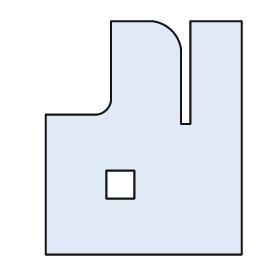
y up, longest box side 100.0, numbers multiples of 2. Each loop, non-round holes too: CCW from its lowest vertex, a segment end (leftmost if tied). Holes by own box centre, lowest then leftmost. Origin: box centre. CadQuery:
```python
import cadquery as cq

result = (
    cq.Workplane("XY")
    .moveTo(-42.0, -50.0)
    .lineTo(42.0, -50.0)
    .lineTo(42.0, 50.0)
    .lineTo(20.0, 50.0)
    .lineTo(20.0, 6.0)
    .lineTo(16.0, 6.0)
    .lineTo(16.0, 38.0)
    .threePointArc((12.0, 46.0), (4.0, 50.0))
    .lineTo(-14.0, 50.0)
    .lineTo(-14.0, 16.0)
    .threePointArc((-16.0, 12.0), (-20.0, 10.0))
    .lineTo(-42.0, 10.0)
    .close()
    .moveTo(-16.0, -26.0)
    .lineTo(-4.0, -26.0)
    .lineTo(-4.0, -14.0)
    .lineTo(-16.0, -14.0)
    .close()
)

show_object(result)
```